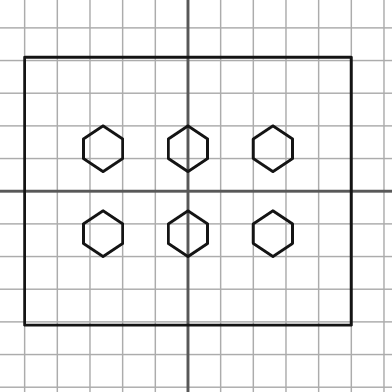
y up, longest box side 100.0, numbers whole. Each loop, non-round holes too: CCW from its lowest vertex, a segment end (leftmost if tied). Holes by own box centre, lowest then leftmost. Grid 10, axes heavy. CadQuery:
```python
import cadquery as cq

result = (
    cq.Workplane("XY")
    .moveTo(-50.0, -41.0)
    .lineTo(50.0, -41.0)
    .lineTo(50.0, 41.0)
    .lineTo(-50.0, 41.0)
    .close()
    .moveTo(-26.0, -20.0)
    .lineTo(-20.0, -16.0)
    .lineTo(-20.0, -10.0)
    .lineTo(-26.0, -6.0)
    .lineTo(-32.0, -10.0)
    .lineTo(-32.0, -16.0)
    .close()
    .moveTo(0.0, -20.0)
    .lineTo(6.0, -16.0)
    .lineTo(6.0, -10.0)
    .lineTo(0.0, -6.0)
    .lineTo(-6.0, -10.0)
    .lineTo(-6.0, -16.0)
    .close()
    .moveTo(26.0, -20.0)
    .lineTo(32.0, -16.0)
    .lineTo(32.0, -10.0)
    .lineTo(26.0, -6.0)
    .lineTo(20.0, -10.0)
    .lineTo(20.0, -16.0)
    .close()
    .moveTo(-26.0, 6.0)
    .lineTo(-20.0, 10.0)
    .lineTo(-20.0, 16.0)
    .lineTo(-26.0, 20.0)
    .lineTo(-32.0, 16.0)
    .lineTo(-32.0, 10.0)
    .close()
    .moveTo(0.0, 6.0)
    .lineTo(6.0, 10.0)
    .lineTo(6.0, 16.0)
    .lineTo(0.0, 20.0)
    .lineTo(-6.0, 16.0)
    .lineTo(-6.0, 10.0)
    .close()
    .moveTo(26.0, 6.0)
    .lineTo(32.0, 10.0)
    .lineTo(32.0, 16.0)
    .lineTo(26.0, 20.0)
    .lineTo(20.0, 16.0)
    .lineTo(20.0, 10.0)
    .close()
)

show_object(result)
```